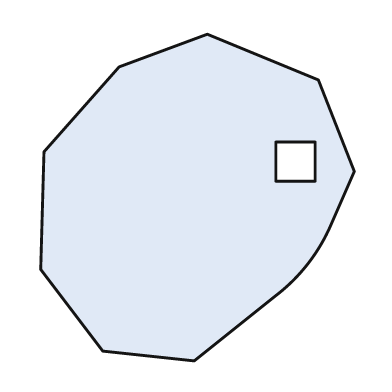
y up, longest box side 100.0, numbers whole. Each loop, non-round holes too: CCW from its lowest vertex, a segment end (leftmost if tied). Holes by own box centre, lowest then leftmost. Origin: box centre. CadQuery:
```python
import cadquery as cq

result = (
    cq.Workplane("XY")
    .moveTo(-1.0, -50.0)
    .lineTo(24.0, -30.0)
    .threePointArc((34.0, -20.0), (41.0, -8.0))
    .lineTo(48.0, 8.0)
    .lineTo(37.0, 36.0)
    .lineTo(3.0, 50.0)
    .lineTo(-24.0, 40.0)
    .lineTo(-47.0, 14.0)
    .lineTo(-48.0, -22.0)
    .lineTo(-29.0, -47.0)
    .close()
    .moveTo(24.0, 5.0)
    .lineTo(36.0, 5.0)
    .lineTo(36.0, 17.0)
    .lineTo(24.0, 17.0)
    .close()
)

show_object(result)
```